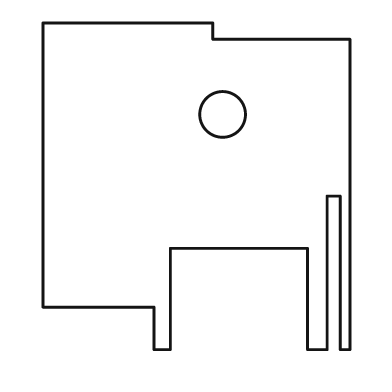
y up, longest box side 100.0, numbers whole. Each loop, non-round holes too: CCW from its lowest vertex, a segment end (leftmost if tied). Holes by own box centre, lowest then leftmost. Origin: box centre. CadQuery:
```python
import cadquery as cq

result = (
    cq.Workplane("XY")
    .moveTo(-13.0, -50.0)
    .lineTo(-8.0, -50.0)
    .lineTo(-8.0, -19.0)
    .lineTo(34.0, -19.0)
    .lineTo(34.0, -50.0)
    .lineTo(40.0, -50.0)
    .lineTo(40.0, -3.0)
    .lineTo(44.0, -3.0)
    .lineTo(44.0, -50.0)
    .lineTo(47.0, -50.0)
    .lineTo(47.0, 45.0)
    .lineTo(5.0, 45.0)
    .lineTo(5.0, 50.0)
    .lineTo(-47.0, 50.0)
    .lineTo(-47.0, -37.0)
    .lineTo(-13.0, -37.0)
    .close()
    .moveTo(8.0, 22.0)
    .circle(7.0)
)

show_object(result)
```